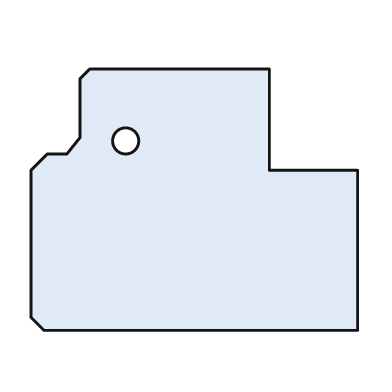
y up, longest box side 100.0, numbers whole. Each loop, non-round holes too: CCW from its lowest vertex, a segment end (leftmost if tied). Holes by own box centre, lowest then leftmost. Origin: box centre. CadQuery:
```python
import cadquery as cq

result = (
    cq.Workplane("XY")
    .moveTo(-46.0, -40.0)
    .lineTo(50.0, -40.0)
    .lineTo(50.0, 9.0)
    .lineTo(23.0, 9.0)
    .lineTo(23.0, 40.0)
    .lineTo(-32.0, 40.0)
    .lineTo(-35.0, 37.0)
    .lineTo(-35.0, 19.0)
    .lineTo(-39.0, 14.0)
    .lineTo(-45.0, 14.0)
    .lineTo(-50.0, 9.0)
    .lineTo(-50.0, -36.0)
    .close()
    .moveTo(-21.0, 18.0)
    .circle(4.0)
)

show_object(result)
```